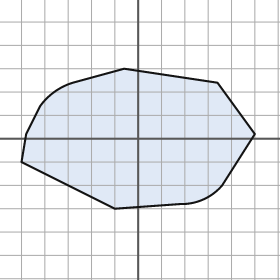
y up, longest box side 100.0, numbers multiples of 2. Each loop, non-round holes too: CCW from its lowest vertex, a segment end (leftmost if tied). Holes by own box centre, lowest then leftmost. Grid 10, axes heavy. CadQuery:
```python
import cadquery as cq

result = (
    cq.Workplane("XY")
    .moveTo(-10.0, -30.0)
    .lineTo(18.0, -28.0)
    .threePointArc((28.0, -26.0), (36.0, -20.0))
    .lineTo(50.0, 2.0)
    .lineTo(34.0, 24.0)
    .lineTo(-6.0, 30.0)
    .lineTo(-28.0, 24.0)
    .threePointArc((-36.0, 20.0), (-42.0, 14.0))
    .lineTo(-48.0, 2.0)
    .lineTo(-50.0, -10.0)
    .close()
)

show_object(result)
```